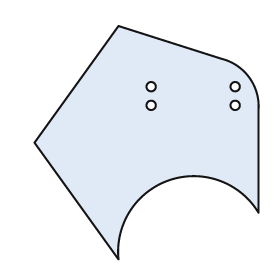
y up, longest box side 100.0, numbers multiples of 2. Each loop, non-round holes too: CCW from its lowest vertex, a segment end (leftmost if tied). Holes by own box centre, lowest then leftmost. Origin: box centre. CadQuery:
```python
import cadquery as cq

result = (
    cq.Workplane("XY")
    .moveTo(-12.0, -50.0)
    .threePointArc((10.0, -16.0), (48.0, -30.0))
    .lineTo(48.0, 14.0)
    .threePointArc((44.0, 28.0), (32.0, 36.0))
    .lineTo(-12.0, 50.0)
    .lineTo(-48.0, 0.0)
    .close()
    .moveTo(2.0, 16.0)
    .circle(2.0)
    .moveTo(38.0, 16.0)
    .circle(2.0)
    .moveTo(2.0, 24.0)
    .circle(2.0)
    .moveTo(38.0, 24.0)
    .circle(2.0)
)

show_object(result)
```